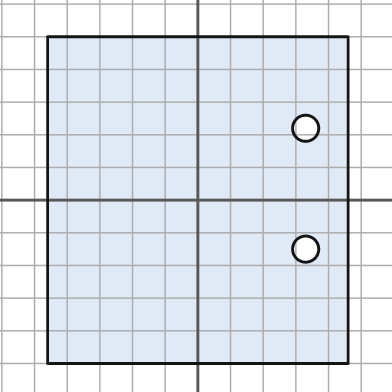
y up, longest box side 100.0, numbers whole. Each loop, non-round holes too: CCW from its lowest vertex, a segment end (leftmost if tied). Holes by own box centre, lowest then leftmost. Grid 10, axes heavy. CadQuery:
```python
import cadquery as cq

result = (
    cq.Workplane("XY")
    .moveTo(-46.0, -50.0)
    .lineTo(46.0, -50.0)
    .lineTo(46.0, 50.0)
    .lineTo(-46.0, 50.0)
    .close()
    .moveTo(33.0, -15.0)
    .circle(4.0)
    .moveTo(33.0, 22.0)
    .circle(4.0)
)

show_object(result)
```